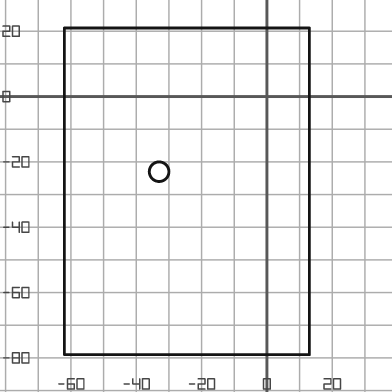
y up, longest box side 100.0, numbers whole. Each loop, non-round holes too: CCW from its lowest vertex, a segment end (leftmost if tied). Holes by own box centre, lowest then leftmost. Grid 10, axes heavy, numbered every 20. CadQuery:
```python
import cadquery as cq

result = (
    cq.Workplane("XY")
    .moveTo(-62.0, -79.0)
    .lineTo(13.0, -79.0)
    .lineTo(13.0, 21.0)
    .lineTo(-62.0, 21.0)
    .close()
    .moveTo(-33.0, -23.0)
    .circle(3.0)
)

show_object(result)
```